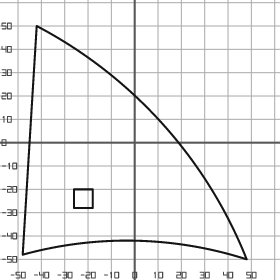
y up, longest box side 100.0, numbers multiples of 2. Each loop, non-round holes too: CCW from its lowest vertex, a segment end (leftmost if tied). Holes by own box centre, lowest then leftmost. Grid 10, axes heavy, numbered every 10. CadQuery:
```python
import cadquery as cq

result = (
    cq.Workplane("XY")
    .moveTo(48.0, -50.0)
    .threePointArc((12.0, 8.0), (-42.0, 50.0))
    .lineTo(-48.0, -48.0)
    .threePointArc((0.0, -42.0), (48.0, -50.0))
    .close()
    .moveTo(-26.0, -28.0)
    .lineTo(-18.0, -28.0)
    .lineTo(-18.0, -20.0)
    .lineTo(-26.0, -20.0)
    .close()
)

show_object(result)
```